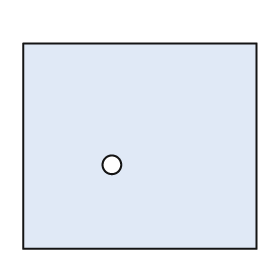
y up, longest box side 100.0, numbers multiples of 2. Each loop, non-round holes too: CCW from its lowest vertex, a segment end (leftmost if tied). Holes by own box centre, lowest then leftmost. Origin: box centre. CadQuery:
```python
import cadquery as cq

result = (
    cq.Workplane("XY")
    .moveTo(-50.0, -44.0)
    .lineTo(50.0, -44.0)
    .lineTo(50.0, 44.0)
    .lineTo(-50.0, 44.0)
    .close()
    .moveTo(-12.0, -8.0)
    .circle(4.0)
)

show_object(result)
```